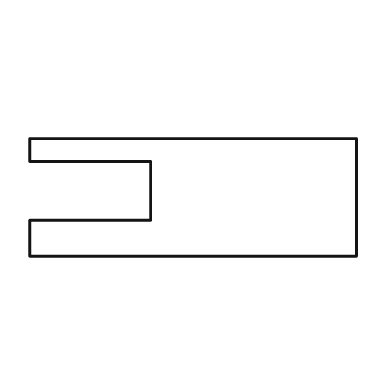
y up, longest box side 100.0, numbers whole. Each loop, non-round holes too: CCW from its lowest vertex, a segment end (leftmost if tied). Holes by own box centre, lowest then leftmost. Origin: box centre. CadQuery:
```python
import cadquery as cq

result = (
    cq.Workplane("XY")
    .moveTo(-50.0, -18.0)
    .lineTo(50.0, -18.0)
    .lineTo(50.0, 18.0)
    .lineTo(-50.0, 18.0)
    .lineTo(-50.0, 11.0)
    .lineTo(-13.0, 11.0)
    .lineTo(-13.0, -7.0)
    .lineTo(-50.0, -7.0)
    .close()
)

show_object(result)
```